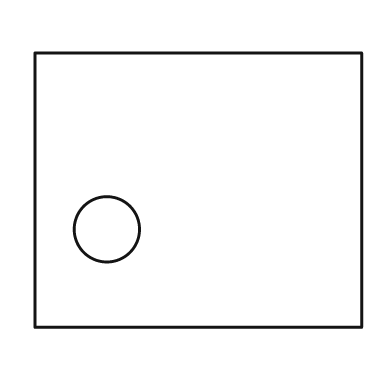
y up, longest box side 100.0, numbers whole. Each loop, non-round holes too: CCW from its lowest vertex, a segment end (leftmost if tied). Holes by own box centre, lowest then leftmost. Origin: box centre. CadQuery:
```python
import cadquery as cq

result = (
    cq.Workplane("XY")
    .moveTo(-50.0, -42.0)
    .lineTo(50.0, -42.0)
    .lineTo(50.0, 42.0)
    .lineTo(-50.0, 42.0)
    .close()
    .moveTo(-28.0, -12.0)
    .circle(10.0)
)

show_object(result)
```